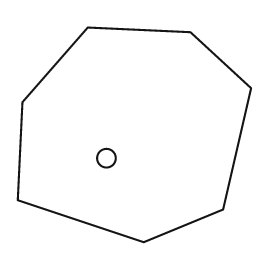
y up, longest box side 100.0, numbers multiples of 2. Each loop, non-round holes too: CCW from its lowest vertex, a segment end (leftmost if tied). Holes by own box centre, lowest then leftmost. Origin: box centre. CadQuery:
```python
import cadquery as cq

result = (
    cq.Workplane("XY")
    .moveTo(4.0, -46.0)
    .lineTo(38.0, -32.0)
    .lineTo(50.0, 20.0)
    .lineTo(24.0, 44.0)
    .lineTo(-20.0, 46.0)
    .lineTo(-48.0, 14.0)
    .lineTo(-50.0, -28.0)
    .close()
    .moveTo(-12.0, -10.0)
    .circle(4.0)
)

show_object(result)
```